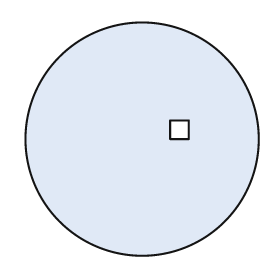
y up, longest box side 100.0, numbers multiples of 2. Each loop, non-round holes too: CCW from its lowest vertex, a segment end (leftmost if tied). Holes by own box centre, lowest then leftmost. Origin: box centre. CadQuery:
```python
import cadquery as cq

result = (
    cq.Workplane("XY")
    .moveTo(0.0, 0.0)
    .circle(50.0)
    .moveTo(12.0, 0.0)
    .lineTo(20.0, 0.0)
    .lineTo(20.0, 8.0)
    .lineTo(12.0, 8.0)
    .close()
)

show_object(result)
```